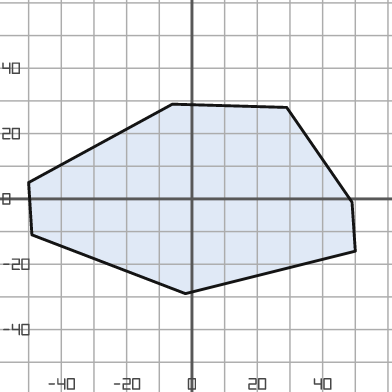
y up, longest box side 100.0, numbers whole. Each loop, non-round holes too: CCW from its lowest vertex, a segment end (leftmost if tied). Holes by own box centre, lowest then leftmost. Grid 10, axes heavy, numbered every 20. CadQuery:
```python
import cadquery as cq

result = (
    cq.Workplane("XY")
    .moveTo(-2.0, -29.0)
    .lineTo(50.0, -16.0)
    .lineTo(49.0, -1.0)
    .lineTo(29.0, 28.0)
    .lineTo(-6.0, 29.0)
    .lineTo(-50.0, 5.0)
    .lineTo(-49.0, -11.0)
    .close()
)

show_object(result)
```